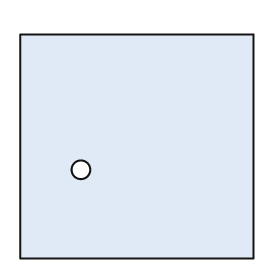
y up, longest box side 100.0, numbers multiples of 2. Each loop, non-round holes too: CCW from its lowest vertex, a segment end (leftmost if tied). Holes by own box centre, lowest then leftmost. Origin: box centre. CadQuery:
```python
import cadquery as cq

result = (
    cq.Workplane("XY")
    .moveTo(-50.0, -48.0)
    .lineTo(50.0, -48.0)
    .lineTo(50.0, 48.0)
    .lineTo(-50.0, 48.0)
    .close()
    .moveTo(-24.0, -10.0)
    .circle(4.0)
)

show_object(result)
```